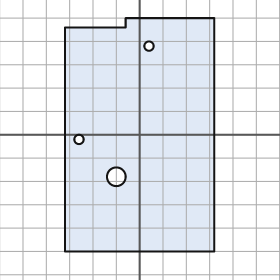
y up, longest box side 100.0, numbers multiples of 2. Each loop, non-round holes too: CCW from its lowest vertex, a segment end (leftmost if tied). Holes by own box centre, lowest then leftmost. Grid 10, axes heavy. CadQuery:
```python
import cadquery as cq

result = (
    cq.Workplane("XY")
    .moveTo(-32.0, -50.0)
    .lineTo(32.0, -50.0)
    .lineTo(32.0, 50.0)
    .lineTo(-6.0, 50.0)
    .lineTo(-6.0, 46.0)
    .lineTo(-32.0, 46.0)
    .close()
    .moveTo(-10.0, -18.0)
    .circle(4.0)
    .moveTo(-26.0, -2.0)
    .circle(2.0)
    .moveTo(4.0, 38.0)
    .circle(2.0)
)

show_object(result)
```